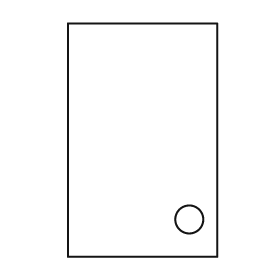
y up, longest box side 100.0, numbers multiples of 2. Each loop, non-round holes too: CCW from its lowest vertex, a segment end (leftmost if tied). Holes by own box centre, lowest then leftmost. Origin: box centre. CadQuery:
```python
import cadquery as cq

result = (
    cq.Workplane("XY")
    .moveTo(-32.0, -50.0)
    .lineTo(32.0, -50.0)
    .lineTo(32.0, 50.0)
    .lineTo(-32.0, 50.0)
    .close()
    .moveTo(20.0, -34.0)
    .circle(6.0)
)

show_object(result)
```